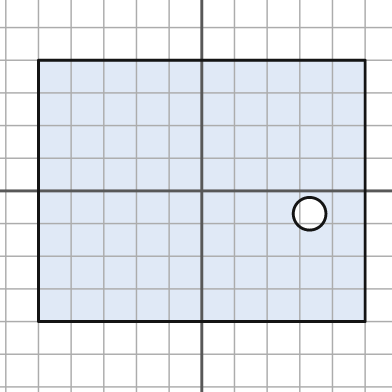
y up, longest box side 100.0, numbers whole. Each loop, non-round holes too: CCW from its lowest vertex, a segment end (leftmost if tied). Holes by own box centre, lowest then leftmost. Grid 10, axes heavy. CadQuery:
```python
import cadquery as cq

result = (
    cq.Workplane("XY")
    .moveTo(-50.0, -40.0)
    .lineTo(50.0, -40.0)
    .lineTo(50.0, 40.0)
    .lineTo(-50.0, 40.0)
    .close()
    .moveTo(33.0, -7.0)
    .circle(5.0)
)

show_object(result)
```